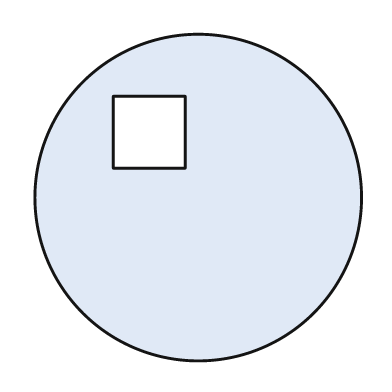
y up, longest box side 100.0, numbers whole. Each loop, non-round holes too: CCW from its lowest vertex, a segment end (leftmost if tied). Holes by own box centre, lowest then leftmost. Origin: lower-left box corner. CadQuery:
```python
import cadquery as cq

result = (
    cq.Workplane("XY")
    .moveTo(50.0, 50.0)
    .circle(50.0)
    .moveTo(24.0, 59.0)
    .lineTo(46.0, 59.0)
    .lineTo(46.0, 81.0)
    .lineTo(24.0, 81.0)
    .close()
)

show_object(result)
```